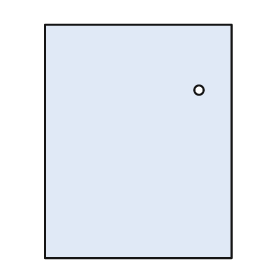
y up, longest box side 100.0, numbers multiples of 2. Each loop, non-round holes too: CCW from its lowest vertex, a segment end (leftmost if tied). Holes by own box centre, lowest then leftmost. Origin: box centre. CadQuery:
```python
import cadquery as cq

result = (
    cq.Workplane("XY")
    .moveTo(-40.0, -50.0)
    .lineTo(40.0, -50.0)
    .lineTo(40.0, 50.0)
    .lineTo(-40.0, 50.0)
    .close()
    .moveTo(26.0, 22.0)
    .circle(2.0)
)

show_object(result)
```